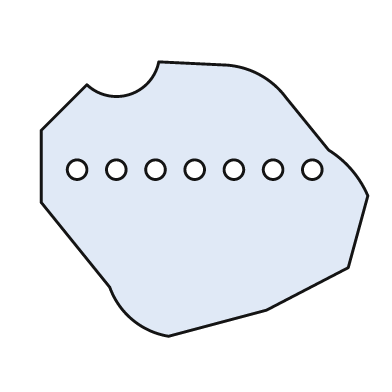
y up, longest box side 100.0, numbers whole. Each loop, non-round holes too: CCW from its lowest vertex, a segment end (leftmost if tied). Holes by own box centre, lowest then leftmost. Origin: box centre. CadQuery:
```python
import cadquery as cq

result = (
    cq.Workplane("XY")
    .moveTo(-11.0, -42.0)
    .lineTo(19.0, -34.0)
    .lineTo(44.0, -21.0)
    .lineTo(50.0, 1.0)
    .threePointArc((45.0, 9.0), (38.0, 15.0))
    .lineTo(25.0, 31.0)
    .threePointArc((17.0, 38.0), (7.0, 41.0))
    .lineTo(-14.0, 42.0)
    .threePointArc((-23.0, 32.0), (-36.0, 35.0))
    .lineTo(-50.0, 21.0)
    .lineTo(-50.0, -1.0)
    .lineTo(-29.0, -27.0)
    .threePointArc((-22.0, -37.0), (-11.0, -42.0))
    .close()
    .moveTo(-39.0, 9.0)
    .circle(3.0)
    .moveTo(-27.0, 9.0)
    .circle(3.0)
    .moveTo(-15.0, 9.0)
    .circle(3.0)
    .moveTo(-3.0, 9.0)
    .circle(3.0)
    .moveTo(9.0, 9.0)
    .circle(3.0)
    .moveTo(21.0, 9.0)
    .circle(3.0)
    .moveTo(33.0, 9.0)
    .circle(3.0)
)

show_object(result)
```